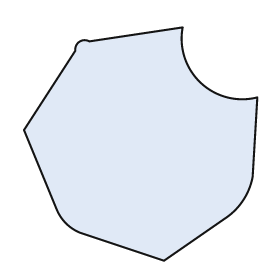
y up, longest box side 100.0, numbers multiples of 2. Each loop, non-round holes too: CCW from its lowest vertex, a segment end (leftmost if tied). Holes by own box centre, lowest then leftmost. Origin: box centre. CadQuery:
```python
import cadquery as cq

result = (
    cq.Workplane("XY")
    .moveTo(10.0, -50.0)
    .lineTo(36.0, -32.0)
    .threePointArc((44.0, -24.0), (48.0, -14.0))
    .lineTo(50.0, 20.0)
    .threePointArc((26.0, 26.0), (18.0, 50.0))
    .lineTo(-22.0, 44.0)
    .threePointArc((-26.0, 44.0), (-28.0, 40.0))
    .lineTo(-50.0, 6.0)
    .lineTo(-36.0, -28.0)
    .threePointArc((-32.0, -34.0), (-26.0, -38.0))
    .close()
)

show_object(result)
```